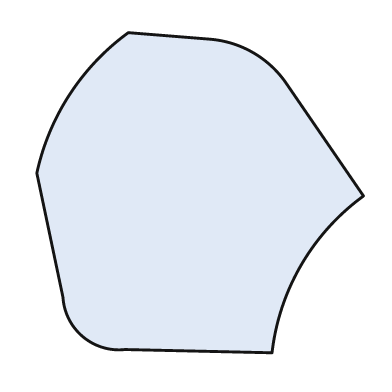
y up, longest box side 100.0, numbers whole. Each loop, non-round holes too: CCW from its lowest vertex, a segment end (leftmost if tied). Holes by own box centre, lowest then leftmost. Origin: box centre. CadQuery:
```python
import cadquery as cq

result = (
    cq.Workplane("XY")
    .moveTo(22.0, -49.0)
    .threePointArc((31.0, -22.0), (50.0, -1.0))
    .lineTo(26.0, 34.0)
    .threePointArc((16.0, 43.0), (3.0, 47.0))
    .lineTo(-22.0, 49.0)
    .threePointArc((-40.0, 30.0), (-50.0, 6.0))
    .lineTo(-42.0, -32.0)
    .threePointArc((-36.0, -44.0), (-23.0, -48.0))
    .close()
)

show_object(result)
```